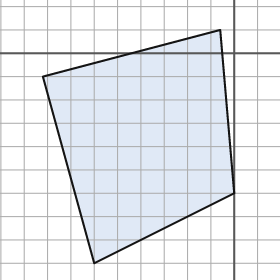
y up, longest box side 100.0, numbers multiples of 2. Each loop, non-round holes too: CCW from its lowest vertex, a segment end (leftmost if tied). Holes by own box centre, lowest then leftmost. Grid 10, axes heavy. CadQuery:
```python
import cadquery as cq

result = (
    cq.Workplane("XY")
    .moveTo(-60.0, -90.0)
    .lineTo(0.0, -60.0)
    .lineTo(-6.0, 10.0)
    .lineTo(-82.0, -10.0)
    .close()
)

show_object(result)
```